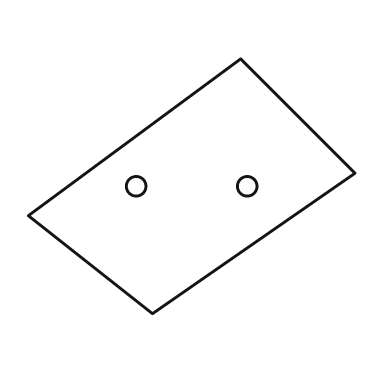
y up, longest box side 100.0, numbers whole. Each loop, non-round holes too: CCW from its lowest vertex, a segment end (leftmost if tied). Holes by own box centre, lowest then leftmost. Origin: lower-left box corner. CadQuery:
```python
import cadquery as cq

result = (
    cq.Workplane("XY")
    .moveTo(38.0, 0.0)
    .lineTo(100.0, 43.0)
    .lineTo(65.0, 78.0)
    .lineTo(0.0, 30.0)
    .close()
    .moveTo(33.0, 39.0)
    .circle(3.0)
    .moveTo(67.0, 39.0)
    .circle(3.0)
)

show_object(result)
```